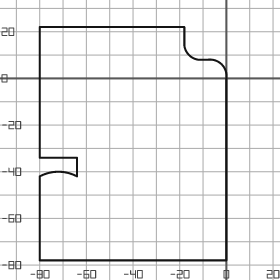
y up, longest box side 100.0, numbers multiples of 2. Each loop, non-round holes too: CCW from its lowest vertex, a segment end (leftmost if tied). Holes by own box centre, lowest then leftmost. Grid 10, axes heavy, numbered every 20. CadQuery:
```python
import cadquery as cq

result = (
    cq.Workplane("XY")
    .moveTo(-80.0, -78.0)
    .lineTo(0.0, -78.0)
    .lineTo(0.0, 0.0)
    .threePointArc((-2.0, 6.0), (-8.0, 8.0))
    .lineTo(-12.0, 8.0)
    .threePointArc((-16.0, 10.0), (-18.0, 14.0))
    .lineTo(-18.0, 22.0)
    .lineTo(-80.0, 22.0)
    .lineTo(-80.0, -34.0)
    .lineTo(-64.0, -34.0)
    .lineTo(-64.0, -42.0)
    .threePointArc((-72.0, -40.0), (-80.0, -42.0))
    .close()
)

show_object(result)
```